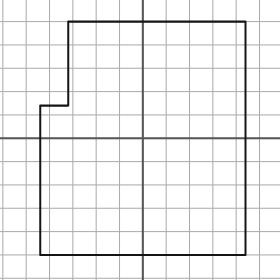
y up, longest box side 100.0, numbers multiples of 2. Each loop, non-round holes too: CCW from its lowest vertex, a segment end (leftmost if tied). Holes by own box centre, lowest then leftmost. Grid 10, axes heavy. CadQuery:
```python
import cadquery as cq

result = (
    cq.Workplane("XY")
    .moveTo(-44.0, -50.0)
    .lineTo(44.0, -50.0)
    .lineTo(44.0, 50.0)
    .lineTo(-32.0, 50.0)
    .lineTo(-32.0, 14.0)
    .lineTo(-44.0, 14.0)
    .close()
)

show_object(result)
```